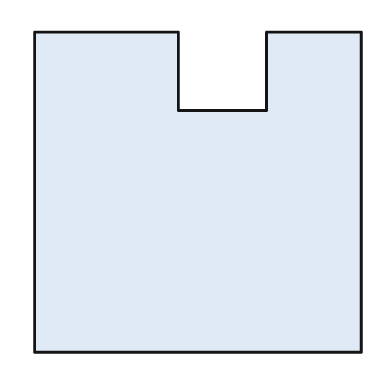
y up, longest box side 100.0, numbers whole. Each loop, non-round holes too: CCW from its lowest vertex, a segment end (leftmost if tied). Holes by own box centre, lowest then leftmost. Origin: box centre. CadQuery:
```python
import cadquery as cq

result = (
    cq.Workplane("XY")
    .moveTo(-50.0, -49.0)
    .lineTo(50.0, -49.0)
    .lineTo(50.0, 49.0)
    .lineTo(21.0, 49.0)
    .lineTo(21.0, 25.0)
    .lineTo(-6.0, 25.0)
    .lineTo(-6.0, 49.0)
    .lineTo(-50.0, 49.0)
    .close()
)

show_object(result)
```